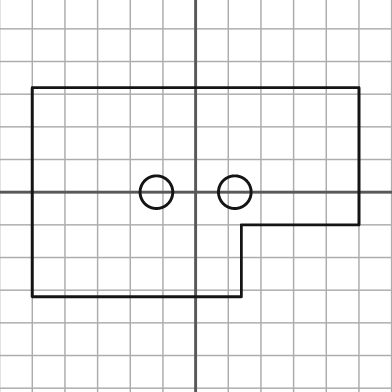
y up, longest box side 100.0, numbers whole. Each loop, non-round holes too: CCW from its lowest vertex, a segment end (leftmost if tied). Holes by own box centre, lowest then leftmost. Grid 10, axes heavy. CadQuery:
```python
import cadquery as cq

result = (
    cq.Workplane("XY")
    .moveTo(-50.0, -32.0)
    .lineTo(14.0, -32.0)
    .lineTo(14.0, -10.0)
    .lineTo(50.0, -10.0)
    .lineTo(50.0, 32.0)
    .lineTo(-50.0, 32.0)
    .close()
    .moveTo(-12.0, 0.0)
    .circle(5.0)
    .moveTo(12.0, 0.0)
    .circle(5.0)
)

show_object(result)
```